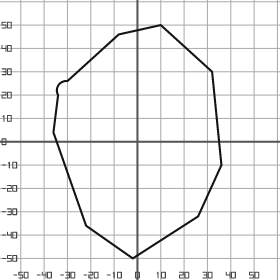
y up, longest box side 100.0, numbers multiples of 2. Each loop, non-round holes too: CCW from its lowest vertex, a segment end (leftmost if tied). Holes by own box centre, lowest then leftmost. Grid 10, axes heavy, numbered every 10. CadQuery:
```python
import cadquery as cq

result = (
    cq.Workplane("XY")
    .moveTo(-2.0, -50.0)
    .lineTo(26.0, -32.0)
    .lineTo(36.0, -10.0)
    .lineTo(32.0, 30.0)
    .lineTo(10.0, 50.0)
    .lineTo(-8.0, 46.0)
    .lineTo(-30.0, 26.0)
    .threePointArc((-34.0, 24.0), (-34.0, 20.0))
    .lineTo(-36.0, 4.0)
    .lineTo(-22.0, -36.0)
    .close()
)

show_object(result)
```